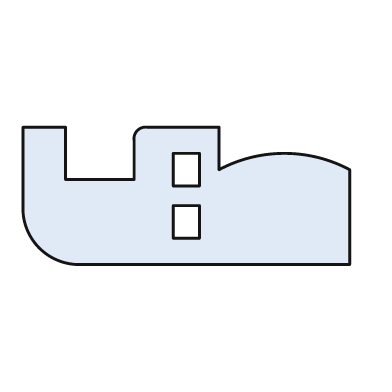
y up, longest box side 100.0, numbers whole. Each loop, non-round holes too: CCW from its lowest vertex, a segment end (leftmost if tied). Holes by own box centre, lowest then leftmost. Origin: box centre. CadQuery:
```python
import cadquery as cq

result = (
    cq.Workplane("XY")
    .moveTo(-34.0, -21.0)
    .lineTo(50.0, -21.0)
    .lineTo(50.0, 8.0)
    .threePointArc((30.0, 13.0), (10.0, 8.0))
    .lineTo(10.0, 21.0)
    .lineTo(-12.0, 21.0)
    .threePointArc((-15.0, 20.0), (-16.0, 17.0))
    .lineTo(-16.0, 5.0)
    .lineTo(-37.0, 5.0)
    .lineTo(-37.0, 21.0)
    .lineTo(-50.0, 21.0)
    .lineTo(-50.0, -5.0)
    .threePointArc((-45.0, -16.0), (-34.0, -21.0))
    .close()
    .moveTo(-4.0, -13.0)
    .lineTo(4.0, -13.0)
    .lineTo(4.0, -3.0)
    .lineTo(-4.0, -3.0)
    .close()
    .moveTo(-4.0, 3.0)
    .lineTo(4.0, 3.0)
    .lineTo(4.0, 13.0)
    .lineTo(-4.0, 13.0)
    .close()
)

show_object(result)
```